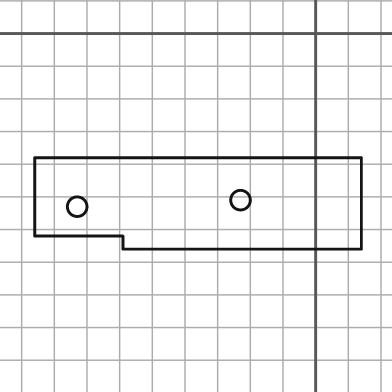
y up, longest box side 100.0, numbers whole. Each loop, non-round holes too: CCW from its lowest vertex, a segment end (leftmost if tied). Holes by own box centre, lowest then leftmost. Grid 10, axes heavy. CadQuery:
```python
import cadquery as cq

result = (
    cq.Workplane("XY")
    .moveTo(-59.0, -66.0)
    .lineTo(14.0, -66.0)
    .lineTo(14.0, -38.0)
    .lineTo(-86.0, -38.0)
    .lineTo(-86.0, -62.0)
    .lineTo(-59.0, -62.0)
    .close()
    .moveTo(-73.0, -53.0)
    .circle(3.0)
    .moveTo(-23.0, -51.0)
    .circle(3.0)
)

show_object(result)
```